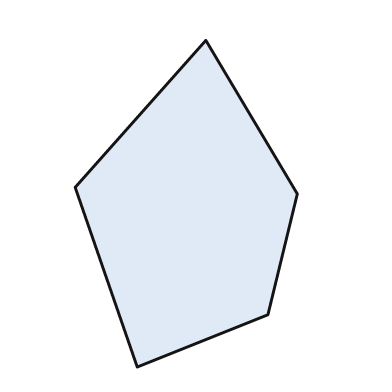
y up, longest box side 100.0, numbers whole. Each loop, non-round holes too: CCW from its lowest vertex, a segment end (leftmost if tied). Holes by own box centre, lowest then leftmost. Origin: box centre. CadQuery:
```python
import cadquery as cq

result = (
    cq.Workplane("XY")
    .moveTo(-15.0, -50.0)
    .lineTo(25.0, -34.0)
    .lineTo(34.0, 3.0)
    .lineTo(6.0, 50.0)
    .lineTo(-34.0, 5.0)
    .close()
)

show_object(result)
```